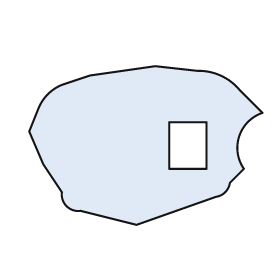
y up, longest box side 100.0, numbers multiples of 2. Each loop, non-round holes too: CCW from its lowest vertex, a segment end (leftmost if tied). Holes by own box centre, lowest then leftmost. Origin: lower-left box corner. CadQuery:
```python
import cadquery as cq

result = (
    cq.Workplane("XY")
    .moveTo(46.0, 0.0)
    .lineTo(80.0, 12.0)
    .threePointArc((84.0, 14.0), (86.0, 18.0))
    .lineTo(92.0, 24.0)
    .threePointArc((90.0, 38.0), (100.0, 48.0))
    .lineTo(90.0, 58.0)
    .threePointArc((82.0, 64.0), (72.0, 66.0))
    .lineTo(54.0, 68.0)
    .lineTo(26.0, 64.0)
    .lineTo(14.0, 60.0)
    .threePointArc((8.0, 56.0), (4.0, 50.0))
    .lineTo(0.0, 40.0)
    .lineTo(6.0, 26.0)
    .lineTo(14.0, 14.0)
    .threePointArc((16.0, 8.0), (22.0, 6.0))
    .close()
    .moveTo(60.0, 24.0)
    .lineTo(76.0, 24.0)
    .lineTo(76.0, 44.0)
    .lineTo(60.0, 44.0)
    .close()
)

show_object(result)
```